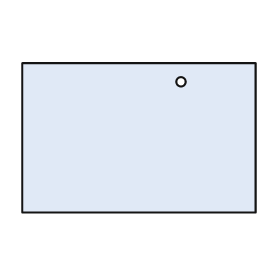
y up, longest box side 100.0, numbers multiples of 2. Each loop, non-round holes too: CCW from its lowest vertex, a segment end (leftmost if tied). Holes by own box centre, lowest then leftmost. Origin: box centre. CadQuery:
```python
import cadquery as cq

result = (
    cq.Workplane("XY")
    .moveTo(-50.0, -32.0)
    .lineTo(50.0, -32.0)
    .lineTo(50.0, 32.0)
    .lineTo(-50.0, 32.0)
    .close()
    .moveTo(18.0, 24.0)
    .circle(2.0)
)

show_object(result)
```